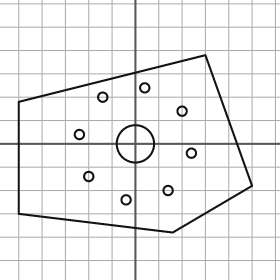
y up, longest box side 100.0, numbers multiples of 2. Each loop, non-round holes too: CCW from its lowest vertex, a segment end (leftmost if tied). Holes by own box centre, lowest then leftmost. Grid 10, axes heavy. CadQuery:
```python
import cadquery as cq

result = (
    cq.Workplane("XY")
    .moveTo(16.0, -38.0)
    .lineTo(50.0, -18.0)
    .lineTo(30.0, 38.0)
    .lineTo(-50.0, 18.0)
    .lineTo(-50.0, -30.0)
    .close()
    .moveTo(-4.0, -24.0)
    .circle(2.0)
    .moveTo(14.0, -20.0)
    .circle(2.0)
    .moveTo(-20.0, -14.0)
    .circle(2.0)
    .moveTo(24.0, -4.0)
    .circle(2.0)
    .moveTo(0.0, 0.0)
    .circle(8.0)
    .moveTo(-24.0, 4.0)
    .circle(2.0)
    .moveTo(20.0, 14.0)
    .circle(2.0)
    .moveTo(-14.0, 20.0)
    .circle(2.0)
    .moveTo(4.0, 24.0)
    .circle(2.0)
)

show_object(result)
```